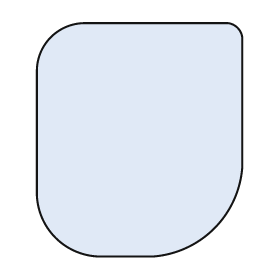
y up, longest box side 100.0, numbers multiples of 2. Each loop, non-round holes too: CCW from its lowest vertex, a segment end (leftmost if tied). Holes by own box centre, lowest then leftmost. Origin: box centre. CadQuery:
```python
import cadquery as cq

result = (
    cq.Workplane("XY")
    .moveTo(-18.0, -50.0)
    .lineTo(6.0, -50.0)
    .threePointArc((32.0, -38.0), (44.0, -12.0))
    .lineTo(44.0, 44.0)
    .threePointArc((42.0, 48.0), (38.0, 50.0))
    .lineTo(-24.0, 50.0)
    .threePointArc((-38.0, 44.0), (-44.0, 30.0))
    .lineTo(-44.0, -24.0)
    .threePointArc((-36.0, -42.0), (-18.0, -50.0))
    .close()
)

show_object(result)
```